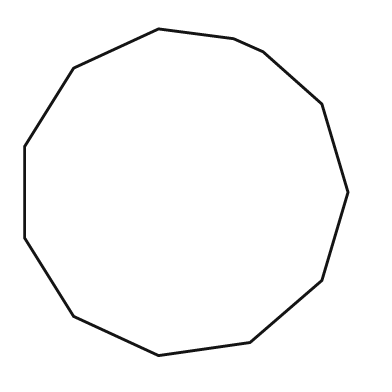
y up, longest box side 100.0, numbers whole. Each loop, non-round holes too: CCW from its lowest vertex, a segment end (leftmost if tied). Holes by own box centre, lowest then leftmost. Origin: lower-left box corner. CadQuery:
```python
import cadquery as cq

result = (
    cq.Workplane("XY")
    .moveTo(41.0, 0.0)
    .lineTo(69.0, 4.0)
    .lineTo(91.0, 23.0)
    .lineTo(99.0, 50.0)
    .lineTo(91.0, 77.0)
    .lineTo(73.0, 93.0)
    .lineTo(64.0, 97.0)
    .lineTo(41.0, 100.0)
    .lineTo(15.0, 88.0)
    .lineTo(0.0, 64.0)
    .lineTo(0.0, 36.0)
    .lineTo(15.0, 12.0)
    .close()
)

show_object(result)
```